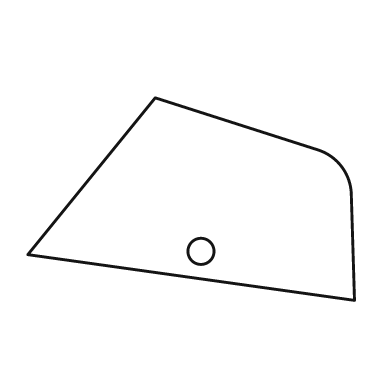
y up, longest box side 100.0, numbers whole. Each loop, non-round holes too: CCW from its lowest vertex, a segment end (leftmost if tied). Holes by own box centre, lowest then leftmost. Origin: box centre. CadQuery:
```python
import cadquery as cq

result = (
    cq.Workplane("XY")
    .moveTo(50.0, -31.0)
    .lineTo(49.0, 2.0)
    .threePointArc((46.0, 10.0), (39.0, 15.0))
    .lineTo(-11.0, 31.0)
    .lineTo(-50.0, -17.0)
    .close()
    .moveTo(3.0, -16.0)
    .circle(4.0)
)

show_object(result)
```